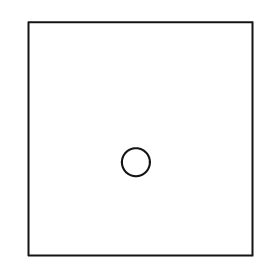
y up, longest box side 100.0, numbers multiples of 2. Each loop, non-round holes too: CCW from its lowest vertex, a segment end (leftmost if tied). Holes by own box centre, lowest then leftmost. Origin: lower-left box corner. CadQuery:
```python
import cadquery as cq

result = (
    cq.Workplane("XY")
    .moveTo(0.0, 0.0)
    .lineTo(96.0, 0.0)
    .lineTo(96.0, 100.0)
    .lineTo(0.0, 100.0)
    .close()
    .moveTo(46.0, 40.0)
    .circle(6.0)
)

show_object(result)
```